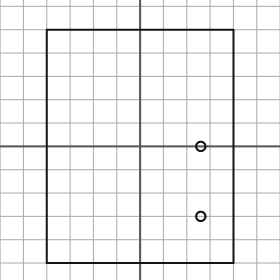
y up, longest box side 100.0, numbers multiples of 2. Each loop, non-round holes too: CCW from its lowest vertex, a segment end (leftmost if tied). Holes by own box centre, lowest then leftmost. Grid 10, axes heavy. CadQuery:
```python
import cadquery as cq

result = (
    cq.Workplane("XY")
    .moveTo(-40.0, -50.0)
    .lineTo(40.0, -50.0)
    .lineTo(40.0, 50.0)
    .lineTo(-40.0, 50.0)
    .close()
    .moveTo(26.0, -30.0)
    .circle(2.0)
    .moveTo(26.0, 0.0)
    .circle(2.0)
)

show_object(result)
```